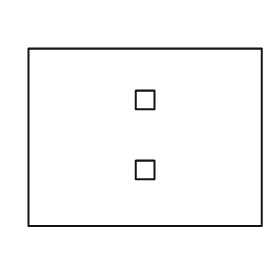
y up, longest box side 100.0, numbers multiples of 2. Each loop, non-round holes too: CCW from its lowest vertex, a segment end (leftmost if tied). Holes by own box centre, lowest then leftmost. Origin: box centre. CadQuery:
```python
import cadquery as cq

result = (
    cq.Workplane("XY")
    .moveTo(-50.0, -38.0)
    .lineTo(50.0, -38.0)
    .lineTo(50.0, 38.0)
    .lineTo(-50.0, 38.0)
    .close()
    .moveTo(-4.0, -18.0)
    .lineTo(4.0, -18.0)
    .lineTo(4.0, -10.0)
    .lineTo(-4.0, -10.0)
    .close()
    .moveTo(-4.0, 12.0)
    .lineTo(4.0, 12.0)
    .lineTo(4.0, 20.0)
    .lineTo(-4.0, 20.0)
    .close()
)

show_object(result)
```